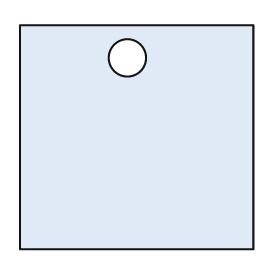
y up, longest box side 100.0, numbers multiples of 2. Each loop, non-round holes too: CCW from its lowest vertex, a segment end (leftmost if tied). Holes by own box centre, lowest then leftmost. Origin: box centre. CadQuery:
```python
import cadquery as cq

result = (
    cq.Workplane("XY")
    .moveTo(-50.0, -48.0)
    .lineTo(50.0, -48.0)
    .lineTo(50.0, 48.0)
    .lineTo(-50.0, 48.0)
    .close()
    .moveTo(-4.0, 34.0)
    .circle(8.0)
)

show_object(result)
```